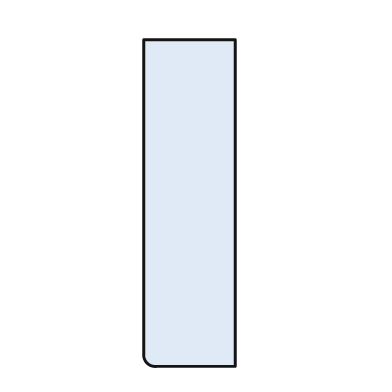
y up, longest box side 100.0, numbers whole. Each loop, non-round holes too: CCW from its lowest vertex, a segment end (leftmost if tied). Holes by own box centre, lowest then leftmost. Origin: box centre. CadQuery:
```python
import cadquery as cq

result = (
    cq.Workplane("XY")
    .moveTo(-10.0, -50.0)
    .lineTo(14.0, -50.0)
    .lineTo(14.0, 50.0)
    .lineTo(-14.0, 50.0)
    .lineTo(-14.0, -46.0)
    .threePointArc((-13.0, -49.0), (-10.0, -50.0))
    .close()
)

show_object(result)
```